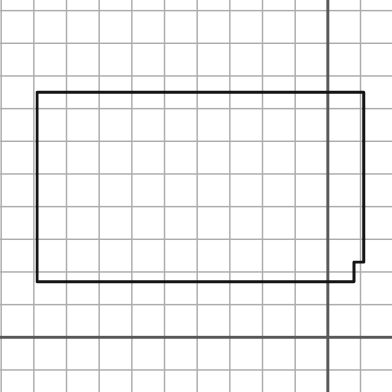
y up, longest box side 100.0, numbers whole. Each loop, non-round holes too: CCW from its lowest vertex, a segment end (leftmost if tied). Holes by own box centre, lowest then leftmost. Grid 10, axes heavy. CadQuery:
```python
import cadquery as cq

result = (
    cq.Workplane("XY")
    .moveTo(-89.0, 17.0)
    .lineTo(8.0, 17.0)
    .lineTo(8.0, 23.0)
    .lineTo(11.0, 23.0)
    .lineTo(11.0, 75.0)
    .lineTo(-89.0, 75.0)
    .close()
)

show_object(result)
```